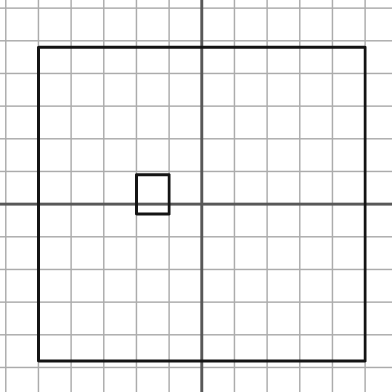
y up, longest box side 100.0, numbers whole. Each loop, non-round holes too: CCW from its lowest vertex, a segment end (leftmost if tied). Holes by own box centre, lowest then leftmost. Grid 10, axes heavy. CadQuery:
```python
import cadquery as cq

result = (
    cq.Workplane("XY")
    .moveTo(-50.0, -48.0)
    .lineTo(50.0, -48.0)
    .lineTo(50.0, 48.0)
    .lineTo(-50.0, 48.0)
    .close()
    .moveTo(-20.0, -3.0)
    .lineTo(-10.0, -3.0)
    .lineTo(-10.0, 9.0)
    .lineTo(-20.0, 9.0)
    .close()
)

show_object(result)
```